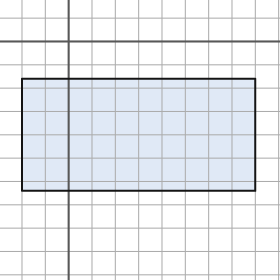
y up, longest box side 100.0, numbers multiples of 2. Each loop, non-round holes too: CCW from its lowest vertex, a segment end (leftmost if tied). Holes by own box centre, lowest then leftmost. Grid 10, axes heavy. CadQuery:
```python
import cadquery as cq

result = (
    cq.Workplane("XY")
    .moveTo(-20.0, -64.0)
    .lineTo(80.0, -64.0)
    .lineTo(80.0, -16.0)
    .lineTo(-20.0, -16.0)
    .close()
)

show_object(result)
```